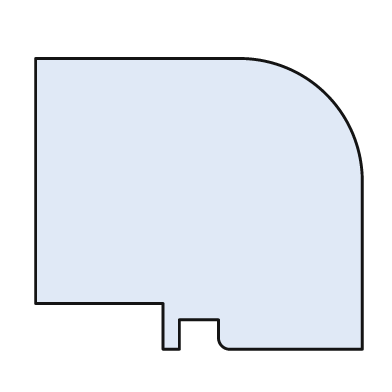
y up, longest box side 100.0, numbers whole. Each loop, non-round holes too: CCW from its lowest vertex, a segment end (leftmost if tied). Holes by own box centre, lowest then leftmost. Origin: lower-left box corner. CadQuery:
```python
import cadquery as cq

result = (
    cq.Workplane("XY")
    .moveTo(39.0, 0.0)
    .lineTo(44.0, 0.0)
    .lineTo(44.0, 9.0)
    .lineTo(56.0, 9.0)
    .lineTo(56.0, 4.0)
    .threePointArc((57.0, 1.0), (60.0, 0.0))
    .lineTo(100.0, 0.0)
    .lineTo(100.0, 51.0)
    .threePointArc((89.0, 78.0), (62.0, 89.0))
    .lineTo(0.0, 89.0)
    .lineTo(0.0, 14.0)
    .lineTo(39.0, 14.0)
    .close()
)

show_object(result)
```